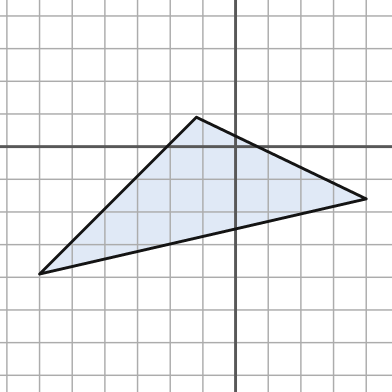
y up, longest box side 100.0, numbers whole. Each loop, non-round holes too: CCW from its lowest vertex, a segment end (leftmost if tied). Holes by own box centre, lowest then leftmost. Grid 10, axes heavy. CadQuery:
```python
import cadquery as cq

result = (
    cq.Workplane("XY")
    .moveTo(-60.0, -39.0)
    .lineTo(40.0, -16.0)
    .lineTo(-12.0, 9.0)
    .close()
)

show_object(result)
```